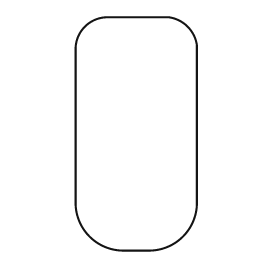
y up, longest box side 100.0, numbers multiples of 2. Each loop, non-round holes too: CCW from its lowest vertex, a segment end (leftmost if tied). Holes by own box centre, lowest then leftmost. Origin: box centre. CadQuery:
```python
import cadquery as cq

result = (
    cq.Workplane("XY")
    .moveTo(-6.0, -50.0)
    .lineTo(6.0, -50.0)
    .threePointArc((20.0, -44.0), (26.0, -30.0))
    .lineTo(26.0, 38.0)
    .threePointArc((22.0, 46.0), (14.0, 50.0))
    .lineTo(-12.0, 50.0)
    .threePointArc((-22.0, 46.0), (-26.0, 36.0))
    .lineTo(-26.0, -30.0)
    .threePointArc((-20.0, -44.0), (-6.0, -50.0))
    .close()
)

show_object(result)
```